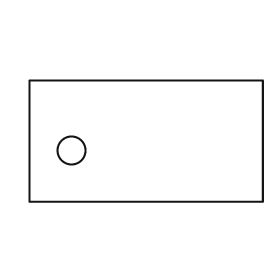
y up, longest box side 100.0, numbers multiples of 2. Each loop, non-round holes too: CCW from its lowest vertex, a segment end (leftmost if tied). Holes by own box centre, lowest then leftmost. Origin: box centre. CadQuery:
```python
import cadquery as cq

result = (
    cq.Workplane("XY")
    .moveTo(-50.0, -26.0)
    .lineTo(50.0, -26.0)
    .lineTo(50.0, 26.0)
    .lineTo(-50.0, 26.0)
    .close()
    .moveTo(-32.0, -4.0)
    .circle(6.0)
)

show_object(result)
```